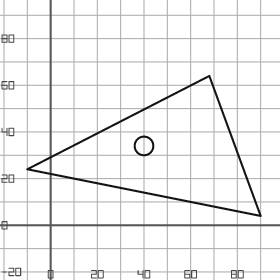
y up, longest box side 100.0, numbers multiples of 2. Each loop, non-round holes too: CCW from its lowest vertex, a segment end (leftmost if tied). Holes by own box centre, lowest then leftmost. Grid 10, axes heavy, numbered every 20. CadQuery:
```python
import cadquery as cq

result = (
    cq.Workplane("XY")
    .moveTo(90.0, 4.0)
    .lineTo(68.0, 64.0)
    .lineTo(-10.0, 24.0)
    .close()
    .moveTo(40.0, 34.0)
    .circle(4.0)
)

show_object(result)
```